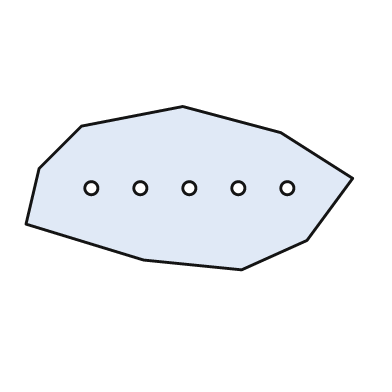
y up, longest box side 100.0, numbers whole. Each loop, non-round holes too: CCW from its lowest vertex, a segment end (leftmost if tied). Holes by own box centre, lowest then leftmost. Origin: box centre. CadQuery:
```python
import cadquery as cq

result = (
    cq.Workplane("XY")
    .moveTo(16.0, -25.0)
    .lineTo(36.0, -16.0)
    .lineTo(50.0, 3.0)
    .lineTo(28.0, 17.0)
    .lineTo(-2.0, 25.0)
    .lineTo(-33.0, 19.0)
    .lineTo(-46.0, 6.0)
    .lineTo(-50.0, -11.0)
    .lineTo(-14.0, -22.0)
    .close()
    .moveTo(-30.0, 0.0)
    .circle(2.0)
    .moveTo(-15.0, 0.0)
    .circle(2.0)
    .moveTo(0.0, 0.0)
    .circle(2.0)
    .moveTo(15.0, 0.0)
    .circle(2.0)
    .moveTo(30.0, 0.0)
    .circle(2.0)
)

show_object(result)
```